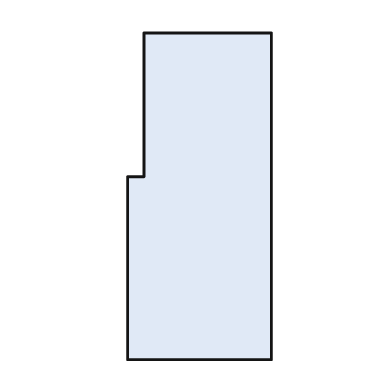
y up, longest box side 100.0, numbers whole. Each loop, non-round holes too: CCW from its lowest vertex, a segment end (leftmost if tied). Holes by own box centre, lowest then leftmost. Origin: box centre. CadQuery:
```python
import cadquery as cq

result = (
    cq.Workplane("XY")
    .moveTo(-22.0, -50.0)
    .lineTo(22.0, -50.0)
    .lineTo(22.0, 50.0)
    .lineTo(-17.0, 50.0)
    .lineTo(-17.0, 6.0)
    .lineTo(-22.0, 6.0)
    .close()
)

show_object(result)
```